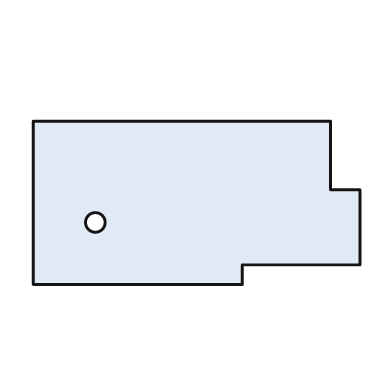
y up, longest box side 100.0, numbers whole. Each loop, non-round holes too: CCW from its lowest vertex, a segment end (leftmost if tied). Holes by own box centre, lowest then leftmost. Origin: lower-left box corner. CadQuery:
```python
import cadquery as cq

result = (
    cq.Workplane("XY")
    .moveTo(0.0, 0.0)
    .lineTo(64.0, 0.0)
    .lineTo(64.0, 6.0)
    .lineTo(100.0, 6.0)
    .lineTo(100.0, 29.0)
    .lineTo(91.0, 29.0)
    .lineTo(91.0, 50.0)
    .lineTo(0.0, 50.0)
    .close()
    .moveTo(19.0, 19.0)
    .circle(3.0)
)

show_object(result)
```